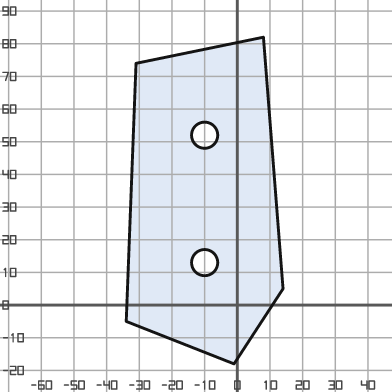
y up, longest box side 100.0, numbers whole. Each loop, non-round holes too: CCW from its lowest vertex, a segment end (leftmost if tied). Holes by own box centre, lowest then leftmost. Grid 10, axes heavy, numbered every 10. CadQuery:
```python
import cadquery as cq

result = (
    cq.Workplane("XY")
    .moveTo(-1.0, -18.0)
    .lineTo(14.0, 5.0)
    .lineTo(8.0, 82.0)
    .lineTo(-31.0, 74.0)
    .lineTo(-34.0, -5.0)
    .close()
    .moveTo(-10.0, 13.0)
    .circle(4.0)
    .moveTo(-10.0, 52.0)
    .circle(4.0)
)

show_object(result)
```